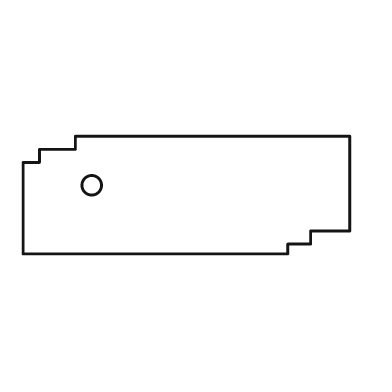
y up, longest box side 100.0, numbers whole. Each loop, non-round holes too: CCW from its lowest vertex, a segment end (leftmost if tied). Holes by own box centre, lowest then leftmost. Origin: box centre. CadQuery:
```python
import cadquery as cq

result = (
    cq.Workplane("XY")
    .moveTo(-50.0, -18.0)
    .lineTo(31.0, -18.0)
    .lineTo(31.0, -15.0)
    .lineTo(38.0, -15.0)
    .lineTo(38.0, -11.0)
    .lineTo(50.0, -11.0)
    .lineTo(50.0, 18.0)
    .lineTo(-34.0, 18.0)
    .lineTo(-34.0, 14.0)
    .lineTo(-45.0, 14.0)
    .lineTo(-45.0, 10.0)
    .lineTo(-50.0, 10.0)
    .close()
    .moveTo(-29.0, 3.0)
    .circle(3.0)
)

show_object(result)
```